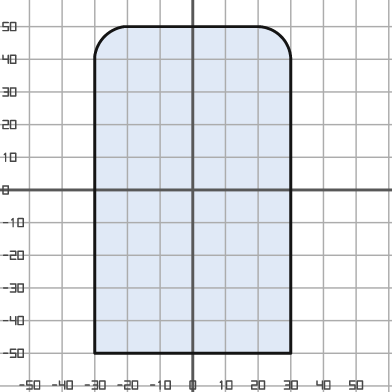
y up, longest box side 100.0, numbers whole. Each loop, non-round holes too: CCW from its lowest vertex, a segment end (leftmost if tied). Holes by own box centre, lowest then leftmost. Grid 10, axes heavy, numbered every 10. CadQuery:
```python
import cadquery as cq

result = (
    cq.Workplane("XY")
    .moveTo(-30.0, -50.0)
    .lineTo(30.0, -50.0)
    .lineTo(30.0, 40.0)
    .threePointArc((27.0, 47.0), (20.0, 50.0))
    .lineTo(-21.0, 50.0)
    .threePointArc((-27.0, 47.0), (-30.0, 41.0))
    .close()
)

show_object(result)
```